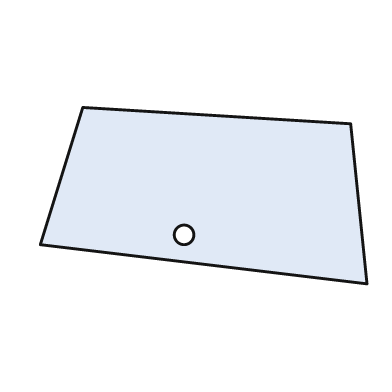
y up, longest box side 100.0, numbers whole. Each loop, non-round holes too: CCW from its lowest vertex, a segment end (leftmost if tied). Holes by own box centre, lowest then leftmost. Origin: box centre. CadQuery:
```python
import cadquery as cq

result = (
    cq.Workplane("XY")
    .moveTo(50.0, -27.0)
    .lineTo(45.0, 22.0)
    .lineTo(-37.0, 27.0)
    .lineTo(-50.0, -15.0)
    .close()
    .moveTo(-6.0, -12.0)
    .circle(3.0)
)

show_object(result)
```